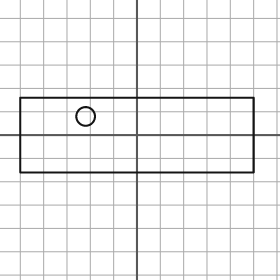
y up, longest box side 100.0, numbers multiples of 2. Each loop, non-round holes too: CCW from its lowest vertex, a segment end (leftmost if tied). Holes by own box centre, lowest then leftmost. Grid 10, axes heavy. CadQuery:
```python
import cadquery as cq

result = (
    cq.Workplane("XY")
    .moveTo(-50.0, -16.0)
    .lineTo(50.0, -16.0)
    .lineTo(50.0, 16.0)
    .lineTo(-50.0, 16.0)
    .close()
    .moveTo(-22.0, 8.0)
    .circle(4.0)
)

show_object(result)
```